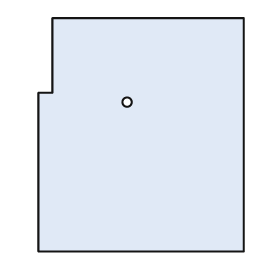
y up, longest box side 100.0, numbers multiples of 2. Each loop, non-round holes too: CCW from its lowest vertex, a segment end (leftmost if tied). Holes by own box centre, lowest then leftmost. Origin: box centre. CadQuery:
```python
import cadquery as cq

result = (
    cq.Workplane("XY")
    .moveTo(-44.0, -50.0)
    .lineTo(44.0, -50.0)
    .lineTo(44.0, 50.0)
    .lineTo(-38.0, 50.0)
    .lineTo(-38.0, 18.0)
    .lineTo(-44.0, 18.0)
    .close()
    .moveTo(-6.0, 14.0)
    .circle(2.0)
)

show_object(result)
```